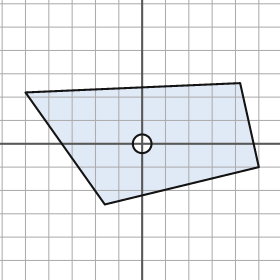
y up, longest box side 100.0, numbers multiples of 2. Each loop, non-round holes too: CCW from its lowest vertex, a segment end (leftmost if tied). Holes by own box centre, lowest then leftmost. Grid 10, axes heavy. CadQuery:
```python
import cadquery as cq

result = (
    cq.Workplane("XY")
    .moveTo(-16.0, -26.0)
    .lineTo(50.0, -10.0)
    .lineTo(42.0, 26.0)
    .lineTo(-50.0, 22.0)
    .close()
    .moveTo(0.0, 0.0)
    .circle(4.0)
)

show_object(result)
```